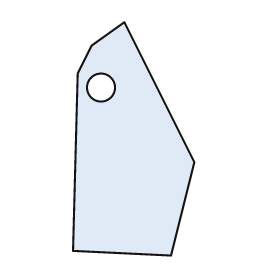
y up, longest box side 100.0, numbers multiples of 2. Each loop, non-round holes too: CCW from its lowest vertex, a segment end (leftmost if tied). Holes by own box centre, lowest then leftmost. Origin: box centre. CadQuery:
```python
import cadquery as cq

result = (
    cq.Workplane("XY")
    .moveTo(16.0, -50.0)
    .lineTo(26.0, -10.0)
    .lineTo(-4.0, 50.0)
    .lineTo(-18.0, 40.0)
    .lineTo(-24.0, 28.0)
    .lineTo(-26.0, -48.0)
    .close()
    .moveTo(-14.0, 22.0)
    .circle(6.0)
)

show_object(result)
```